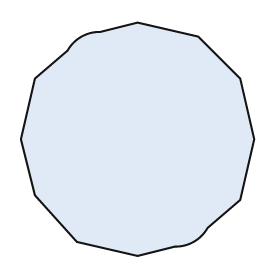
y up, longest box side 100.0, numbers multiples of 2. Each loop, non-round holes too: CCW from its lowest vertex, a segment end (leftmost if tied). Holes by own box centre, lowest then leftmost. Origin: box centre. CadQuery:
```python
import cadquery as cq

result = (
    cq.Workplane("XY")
    .moveTo(0.0, -50.0)
    .lineTo(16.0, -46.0)
    .threePointArc((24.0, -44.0), (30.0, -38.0))
    .lineTo(44.0, -26.0)
    .lineTo(50.0, 0.0)
    .lineTo(44.0, 26.0)
    .lineTo(26.0, 44.0)
    .lineTo(0.0, 50.0)
    .lineTo(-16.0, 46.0)
    .threePointArc((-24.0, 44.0), (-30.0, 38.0))
    .lineTo(-44.0, 26.0)
    .lineTo(-50.0, 0.0)
    .lineTo(-44.0, -24.0)
    .lineTo(-26.0, -44.0)
    .close()
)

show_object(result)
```